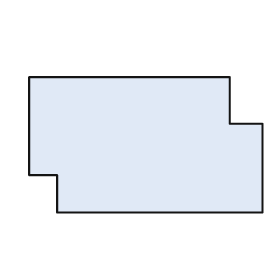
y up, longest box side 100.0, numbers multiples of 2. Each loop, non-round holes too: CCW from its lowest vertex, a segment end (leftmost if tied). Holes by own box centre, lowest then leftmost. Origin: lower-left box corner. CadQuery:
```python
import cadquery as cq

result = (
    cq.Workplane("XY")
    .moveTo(12.0, 0.0)
    .lineTo(100.0, 0.0)
    .lineTo(100.0, 38.0)
    .lineTo(86.0, 38.0)
    .lineTo(86.0, 58.0)
    .lineTo(0.0, 58.0)
    .lineTo(0.0, 16.0)
    .lineTo(12.0, 16.0)
    .close()
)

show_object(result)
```